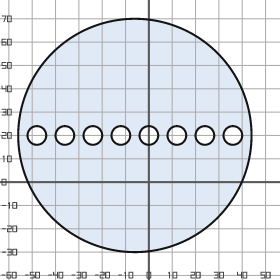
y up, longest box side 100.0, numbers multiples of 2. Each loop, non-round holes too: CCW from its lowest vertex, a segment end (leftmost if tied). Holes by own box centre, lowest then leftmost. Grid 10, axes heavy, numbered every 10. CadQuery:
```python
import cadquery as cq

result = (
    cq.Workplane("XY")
    .moveTo(-6.0, 20.0)
    .circle(50.0)
    .moveTo(-48.0, 20.0)
    .circle(4.0)
    .moveTo(-36.0, 20.0)
    .circle(4.0)
    .moveTo(-24.0, 20.0)
    .circle(4.0)
    .moveTo(-12.0, 20.0)
    .circle(4.0)
    .moveTo(0.0, 20.0)
    .circle(4.0)
    .moveTo(12.0, 20.0)
    .circle(4.0)
    .moveTo(24.0, 20.0)
    .circle(4.0)
    .moveTo(36.0, 20.0)
    .circle(4.0)
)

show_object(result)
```